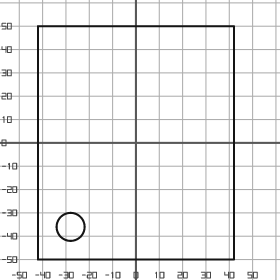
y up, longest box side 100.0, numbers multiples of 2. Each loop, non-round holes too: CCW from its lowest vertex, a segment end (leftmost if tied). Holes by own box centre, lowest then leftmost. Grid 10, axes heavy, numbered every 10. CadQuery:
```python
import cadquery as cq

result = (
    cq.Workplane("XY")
    .moveTo(-42.0, -50.0)
    .lineTo(42.0, -50.0)
    .lineTo(42.0, 50.0)
    .lineTo(-42.0, 50.0)
    .close()
    .moveTo(-28.0, -36.0)
    .circle(6.0)
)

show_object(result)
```